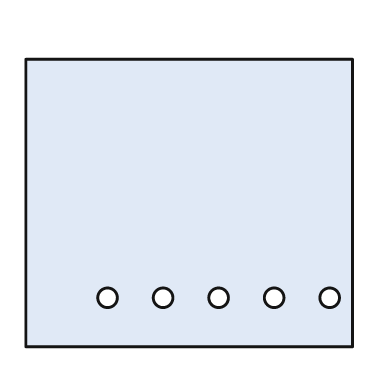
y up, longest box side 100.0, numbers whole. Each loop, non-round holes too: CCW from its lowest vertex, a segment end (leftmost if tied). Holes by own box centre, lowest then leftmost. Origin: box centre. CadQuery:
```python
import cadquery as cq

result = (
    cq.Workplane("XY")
    .moveTo(-50.0, -44.0)
    .lineTo(50.0, -44.0)
    .lineTo(50.0, 44.0)
    .lineTo(-50.0, 44.0)
    .close()
    .moveTo(-25.0, -29.0)
    .circle(3.0)
    .moveTo(-8.0, -29.0)
    .circle(3.0)
    .moveTo(9.0, -29.0)
    .circle(3.0)
    .moveTo(26.0, -29.0)
    .circle(3.0)
    .moveTo(43.0, -29.0)
    .circle(3.0)
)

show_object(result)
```